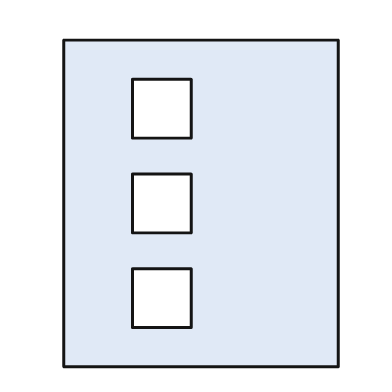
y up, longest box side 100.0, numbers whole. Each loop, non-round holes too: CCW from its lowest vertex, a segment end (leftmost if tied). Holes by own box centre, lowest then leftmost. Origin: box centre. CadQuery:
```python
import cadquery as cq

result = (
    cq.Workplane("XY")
    .moveTo(-42.0, -50.0)
    .lineTo(42.0, -50.0)
    .lineTo(42.0, 50.0)
    .lineTo(-42.0, 50.0)
    .close()
    .moveTo(-21.0, -38.0)
    .lineTo(-3.0, -38.0)
    .lineTo(-3.0, -20.0)
    .lineTo(-21.0, -20.0)
    .close()
    .moveTo(-21.0, -9.0)
    .lineTo(-3.0, -9.0)
    .lineTo(-3.0, 9.0)
    .lineTo(-21.0, 9.0)
    .close()
    .moveTo(-21.0, 20.0)
    .lineTo(-3.0, 20.0)
    .lineTo(-3.0, 38.0)
    .lineTo(-21.0, 38.0)
    .close()
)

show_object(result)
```